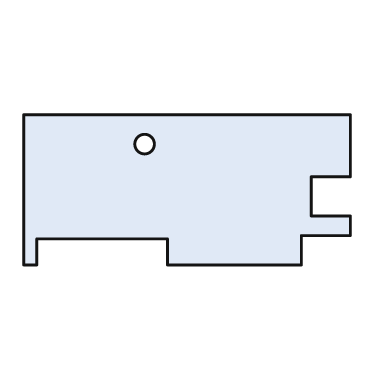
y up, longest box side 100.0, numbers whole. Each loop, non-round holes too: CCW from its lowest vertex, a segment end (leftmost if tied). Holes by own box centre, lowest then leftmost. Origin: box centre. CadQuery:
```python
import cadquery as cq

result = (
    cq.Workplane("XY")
    .moveTo(-50.0, -23.0)
    .lineTo(-46.0, -23.0)
    .lineTo(-46.0, -15.0)
    .lineTo(-6.0, -15.0)
    .lineTo(-6.0, -23.0)
    .lineTo(35.0, -23.0)
    .lineTo(35.0, -14.0)
    .lineTo(50.0, -14.0)
    .lineTo(50.0, -8.0)
    .lineTo(38.0, -8.0)
    .lineTo(38.0, 4.0)
    .lineTo(50.0, 4.0)
    .lineTo(50.0, 23.0)
    .lineTo(-50.0, 23.0)
    .close()
    .moveTo(-13.0, 14.0)
    .circle(3.0)
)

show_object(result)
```